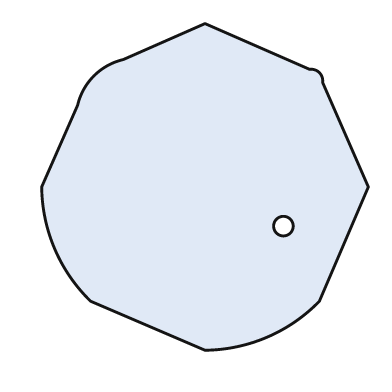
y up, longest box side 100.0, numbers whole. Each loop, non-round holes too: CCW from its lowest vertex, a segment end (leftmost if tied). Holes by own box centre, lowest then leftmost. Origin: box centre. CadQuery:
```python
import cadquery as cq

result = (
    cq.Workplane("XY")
    .moveTo(0.0, -50.0)
    .threePointArc((19.0, -46.0), (35.0, -35.0))
    .lineTo(50.0, 0.0)
    .lineTo(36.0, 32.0)
    .threePointArc((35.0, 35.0), (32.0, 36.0))
    .lineTo(0.0, 50.0)
    .lineTo(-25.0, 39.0)
    .threePointArc((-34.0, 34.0), (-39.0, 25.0))
    .lineTo(-50.0, 0.0)
    .threePointArc((-46.0, -19.0), (-35.0, -35.0))
    .close()
    .moveTo(24.0, -12.0)
    .circle(3.0)
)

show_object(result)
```